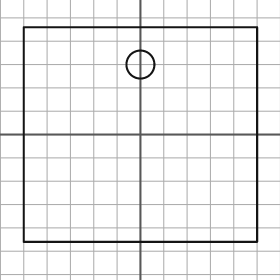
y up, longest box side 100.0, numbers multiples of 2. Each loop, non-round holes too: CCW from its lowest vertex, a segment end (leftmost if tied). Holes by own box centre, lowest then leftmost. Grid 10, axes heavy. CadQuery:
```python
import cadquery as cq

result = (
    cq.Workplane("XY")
    .moveTo(-50.0, -46.0)
    .lineTo(50.0, -46.0)
    .lineTo(50.0, 46.0)
    .lineTo(-50.0, 46.0)
    .close()
    .moveTo(0.0, 30.0)
    .circle(6.0)
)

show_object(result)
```